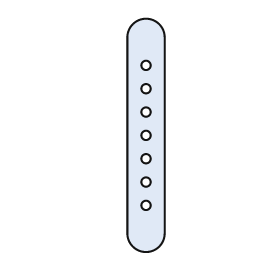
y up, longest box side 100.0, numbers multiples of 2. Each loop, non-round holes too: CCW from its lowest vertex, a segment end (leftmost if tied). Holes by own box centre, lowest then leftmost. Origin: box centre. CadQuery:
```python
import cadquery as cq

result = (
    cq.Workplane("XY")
    .moveTo(-8.0, -42.0)
    .threePointArc((0.0, -50.0), (8.0, -42.0))
    .lineTo(8.0, 42.0)
    .threePointArc((0.0, 50.0), (-8.0, 42.0))
    .close()
    .moveTo(0.0, -30.0)
    .circle(2.0)
    .moveTo(0.0, -20.0)
    .circle(2.0)
    .moveTo(0.0, -10.0)
    .circle(2.0)
    .moveTo(0.0, 0.0)
    .circle(2.0)
    .moveTo(0.0, 10.0)
    .circle(2.0)
    .moveTo(0.0, 20.0)
    .circle(2.0)
    .moveTo(0.0, 30.0)
    .circle(2.0)
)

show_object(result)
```